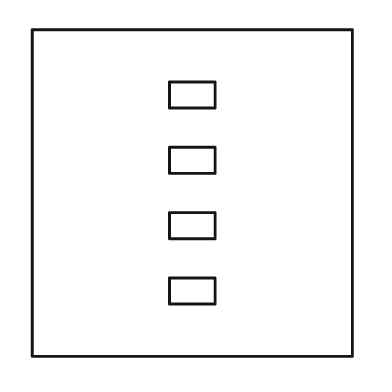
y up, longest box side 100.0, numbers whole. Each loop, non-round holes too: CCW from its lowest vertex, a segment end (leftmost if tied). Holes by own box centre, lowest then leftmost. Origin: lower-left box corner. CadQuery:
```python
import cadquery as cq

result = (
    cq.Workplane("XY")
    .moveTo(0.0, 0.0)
    .lineTo(98.0, 0.0)
    .lineTo(98.0, 100.0)
    .lineTo(0.0, 100.0)
    .close()
    .moveTo(42.0, 16.0)
    .lineTo(56.0, 16.0)
    .lineTo(56.0, 24.0)
    .lineTo(42.0, 24.0)
    .close()
    .moveTo(42.0, 36.0)
    .lineTo(56.0, 36.0)
    .lineTo(56.0, 44.0)
    .lineTo(42.0, 44.0)
    .close()
    .moveTo(42.0, 56.0)
    .lineTo(56.0, 56.0)
    .lineTo(56.0, 64.0)
    .lineTo(42.0, 64.0)
    .close()
    .moveTo(42.0, 76.0)
    .lineTo(56.0, 76.0)
    .lineTo(56.0, 84.0)
    .lineTo(42.0, 84.0)
    .close()
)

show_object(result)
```